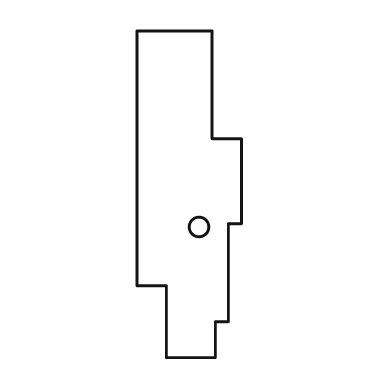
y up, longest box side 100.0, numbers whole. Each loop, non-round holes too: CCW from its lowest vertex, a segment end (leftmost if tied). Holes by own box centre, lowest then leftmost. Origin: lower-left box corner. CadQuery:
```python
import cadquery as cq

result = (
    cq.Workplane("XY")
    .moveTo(9.0, 0.0)
    .lineTo(24.0, 0.0)
    .lineTo(24.0, 11.0)
    .lineTo(28.0, 11.0)
    .lineTo(28.0, 41.0)
    .lineTo(32.0, 41.0)
    .lineTo(32.0, 67.0)
    .lineTo(23.0, 67.0)
    .lineTo(23.0, 100.0)
    .lineTo(0.0, 100.0)
    .lineTo(0.0, 22.0)
    .lineTo(9.0, 22.0)
    .close()
    .moveTo(19.0, 40.0)
    .circle(3.0)
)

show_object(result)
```